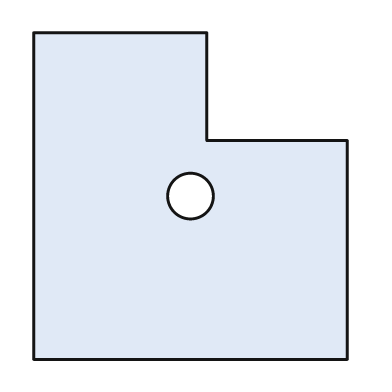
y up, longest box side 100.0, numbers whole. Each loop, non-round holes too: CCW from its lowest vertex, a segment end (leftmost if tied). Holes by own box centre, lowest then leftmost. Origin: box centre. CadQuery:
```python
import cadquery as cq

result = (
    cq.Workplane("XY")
    .moveTo(-48.0, -50.0)
    .lineTo(48.0, -50.0)
    .lineTo(48.0, 17.0)
    .lineTo(5.0, 17.0)
    .lineTo(5.0, 50.0)
    .lineTo(-48.0, 50.0)
    .close()
    .moveTo(0.0, 0.0)
    .circle(7.0)
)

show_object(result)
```